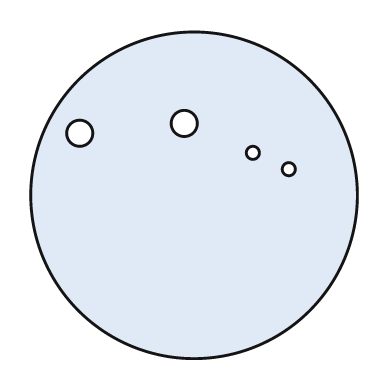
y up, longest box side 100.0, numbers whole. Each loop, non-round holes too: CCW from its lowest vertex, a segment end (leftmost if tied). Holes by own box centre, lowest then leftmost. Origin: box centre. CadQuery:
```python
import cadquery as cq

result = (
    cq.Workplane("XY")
    .moveTo(0.0, 0.0)
    .circle(50.0)
    .moveTo(29.0, 8.0)
    .circle(2.0)
    .moveTo(18.0, 13.0)
    .circle(2.0)
    .moveTo(-35.0, 19.0)
    .circle(4.0)
    .moveTo(-3.0, 22.0)
    .circle(4.0)
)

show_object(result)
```